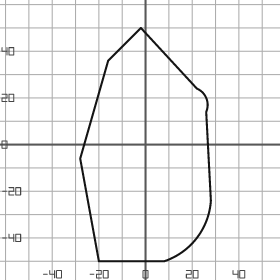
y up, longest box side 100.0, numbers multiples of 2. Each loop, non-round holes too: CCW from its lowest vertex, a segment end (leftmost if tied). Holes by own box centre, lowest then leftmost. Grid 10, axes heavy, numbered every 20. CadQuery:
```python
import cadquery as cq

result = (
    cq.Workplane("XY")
    .moveTo(-20.0, -50.0)
    .lineTo(8.0, -50.0)
    .threePointArc((22.0, -40.0), (28.0, -24.0))
    .lineTo(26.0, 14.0)
    .threePointArc((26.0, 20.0), (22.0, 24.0))
    .lineTo(-2.0, 50.0)
    .lineTo(-16.0, 36.0)
    .lineTo(-28.0, -6.0)
    .close()
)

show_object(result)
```